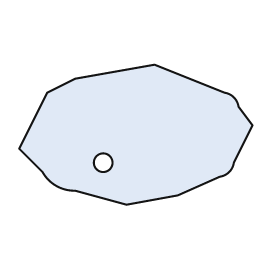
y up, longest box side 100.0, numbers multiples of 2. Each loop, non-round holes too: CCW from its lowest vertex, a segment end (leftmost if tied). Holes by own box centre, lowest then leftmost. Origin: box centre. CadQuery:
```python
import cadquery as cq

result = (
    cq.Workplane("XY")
    .moveTo(-4.0, -30.0)
    .lineTo(18.0, -26.0)
    .lineTo(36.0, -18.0)
    .threePointArc((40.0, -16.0), (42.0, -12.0))
    .lineTo(50.0, 4.0)
    .lineTo(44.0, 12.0)
    .threePointArc((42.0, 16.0), (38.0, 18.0))
    .lineTo(8.0, 30.0)
    .lineTo(-26.0, 24.0)
    .lineTo(-38.0, 18.0)
    .lineTo(-50.0, -6.0)
    .lineTo(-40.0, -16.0)
    .threePointArc((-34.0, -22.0), (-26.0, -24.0))
    .close()
    .moveTo(-14.0, -12.0)
    .circle(4.0)
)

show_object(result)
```